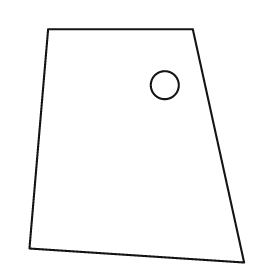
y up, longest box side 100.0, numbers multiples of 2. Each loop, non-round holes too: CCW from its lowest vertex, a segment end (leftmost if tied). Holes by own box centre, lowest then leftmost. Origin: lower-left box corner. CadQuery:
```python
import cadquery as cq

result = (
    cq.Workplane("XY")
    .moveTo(92.0, 0.0)
    .lineTo(70.0, 100.0)
    .lineTo(8.0, 100.0)
    .lineTo(0.0, 6.0)
    .close()
    .moveTo(58.0, 76.0)
    .circle(6.0)
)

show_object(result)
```